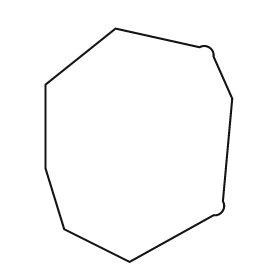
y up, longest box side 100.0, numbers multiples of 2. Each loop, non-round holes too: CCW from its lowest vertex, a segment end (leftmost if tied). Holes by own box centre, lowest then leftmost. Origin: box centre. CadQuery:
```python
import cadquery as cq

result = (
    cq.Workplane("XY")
    .moveTo(-4.0, -50.0)
    .lineTo(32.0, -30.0)
    .threePointArc((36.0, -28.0), (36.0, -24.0))
    .lineTo(40.0, 20.0)
    .lineTo(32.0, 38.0)
    .threePointArc((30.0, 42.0), (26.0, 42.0))
    .lineTo(-10.0, 50.0)
    .lineTo(-40.0, 26.0)
    .lineTo(-40.0, -10.0)
    .lineTo(-32.0, -36.0)
    .close()
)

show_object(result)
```